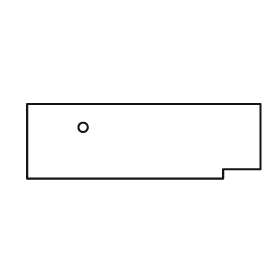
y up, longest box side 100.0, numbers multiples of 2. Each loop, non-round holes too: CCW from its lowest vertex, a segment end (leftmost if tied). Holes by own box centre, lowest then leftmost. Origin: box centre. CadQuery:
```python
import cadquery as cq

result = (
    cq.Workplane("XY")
    .moveTo(-50.0, -16.0)
    .lineTo(34.0, -16.0)
    .lineTo(34.0, -12.0)
    .lineTo(50.0, -12.0)
    .lineTo(50.0, 16.0)
    .lineTo(-50.0, 16.0)
    .close()
    .moveTo(-26.0, 6.0)
    .circle(2.0)
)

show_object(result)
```